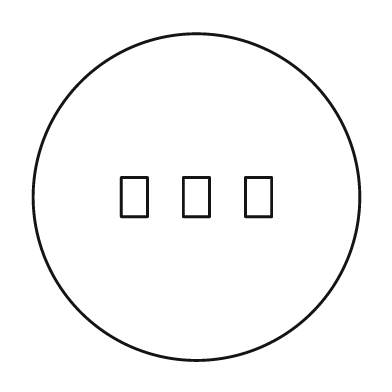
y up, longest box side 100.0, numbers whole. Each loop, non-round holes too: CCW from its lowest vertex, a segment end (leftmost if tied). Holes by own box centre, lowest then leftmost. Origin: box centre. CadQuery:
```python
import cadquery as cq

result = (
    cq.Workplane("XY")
    .moveTo(0.0, 0.0)
    .circle(50.0)
    .moveTo(-23.0, -6.0)
    .lineTo(-15.0, -6.0)
    .lineTo(-15.0, 6.0)
    .lineTo(-23.0, 6.0)
    .close()
    .moveTo(-4.0, -6.0)
    .lineTo(4.0, -6.0)
    .lineTo(4.0, 6.0)
    .lineTo(-4.0, 6.0)
    .close()
    .moveTo(15.0, -6.0)
    .lineTo(23.0, -6.0)
    .lineTo(23.0, 6.0)
    .lineTo(15.0, 6.0)
    .close()
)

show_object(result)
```